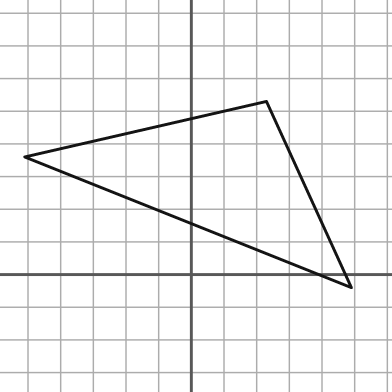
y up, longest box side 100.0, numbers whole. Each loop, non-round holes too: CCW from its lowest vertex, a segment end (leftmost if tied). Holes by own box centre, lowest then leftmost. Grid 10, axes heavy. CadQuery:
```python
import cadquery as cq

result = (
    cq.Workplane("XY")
    .moveTo(49.0, -4.0)
    .lineTo(23.0, 53.0)
    .lineTo(-51.0, 36.0)
    .close()
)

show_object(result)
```